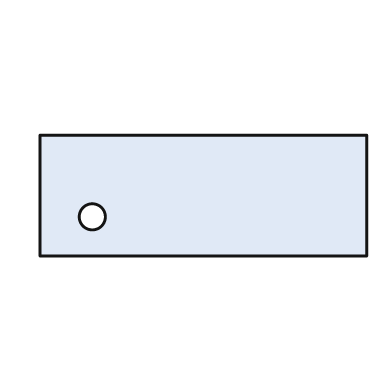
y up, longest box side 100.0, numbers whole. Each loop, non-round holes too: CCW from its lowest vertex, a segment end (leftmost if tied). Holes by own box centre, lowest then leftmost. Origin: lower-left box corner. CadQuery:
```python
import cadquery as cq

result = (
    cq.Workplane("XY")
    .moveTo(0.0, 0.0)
    .lineTo(100.0, 0.0)
    .lineTo(100.0, 37.0)
    .lineTo(0.0, 37.0)
    .close()
    .moveTo(16.0, 12.0)
    .circle(4.0)
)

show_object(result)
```